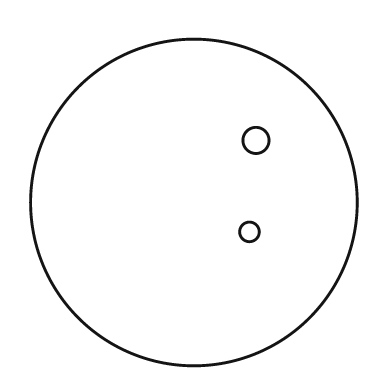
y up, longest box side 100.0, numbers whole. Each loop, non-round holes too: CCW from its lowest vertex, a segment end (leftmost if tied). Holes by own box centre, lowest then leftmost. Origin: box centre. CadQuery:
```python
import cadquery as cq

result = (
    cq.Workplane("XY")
    .moveTo(0.0, 0.0)
    .circle(50.0)
    .moveTo(17.0, -9.0)
    .circle(3.0)
    .moveTo(19.0, 19.0)
    .circle(4.0)
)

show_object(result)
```